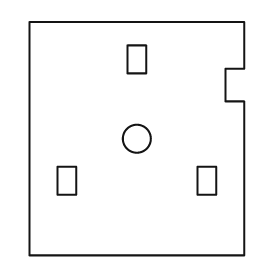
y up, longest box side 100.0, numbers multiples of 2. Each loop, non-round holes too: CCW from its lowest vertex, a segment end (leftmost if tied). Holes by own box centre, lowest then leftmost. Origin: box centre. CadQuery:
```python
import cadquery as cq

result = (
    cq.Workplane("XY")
    .moveTo(-46.0, -50.0)
    .lineTo(46.0, -50.0)
    .lineTo(46.0, 16.0)
    .lineTo(38.0, 16.0)
    .lineTo(38.0, 30.0)
    .lineTo(46.0, 30.0)
    .lineTo(46.0, 50.0)
    .lineTo(-46.0, 50.0)
    .close()
    .moveTo(-34.0, -24.0)
    .lineTo(-26.0, -24.0)
    .lineTo(-26.0, -12.0)
    .lineTo(-34.0, -12.0)
    .close()
    .moveTo(26.0, -24.0)
    .lineTo(34.0, -24.0)
    .lineTo(34.0, -12.0)
    .lineTo(26.0, -12.0)
    .close()
    .moveTo(0.0, 0.0)
    .circle(6.0)
    .moveTo(-4.0, 28.0)
    .lineTo(4.0, 28.0)
    .lineTo(4.0, 40.0)
    .lineTo(-4.0, 40.0)
    .close()
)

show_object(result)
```